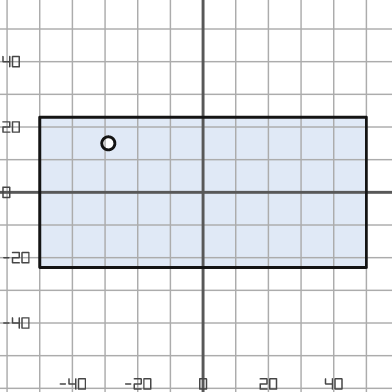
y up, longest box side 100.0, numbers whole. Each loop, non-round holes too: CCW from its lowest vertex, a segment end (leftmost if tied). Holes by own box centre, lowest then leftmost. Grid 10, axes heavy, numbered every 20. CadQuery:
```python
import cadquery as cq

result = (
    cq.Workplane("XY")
    .moveTo(-50.0, -23.0)
    .lineTo(50.0, -23.0)
    .lineTo(50.0, 23.0)
    .lineTo(-50.0, 23.0)
    .close()
    .moveTo(-29.0, 15.0)
    .circle(2.0)
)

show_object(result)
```